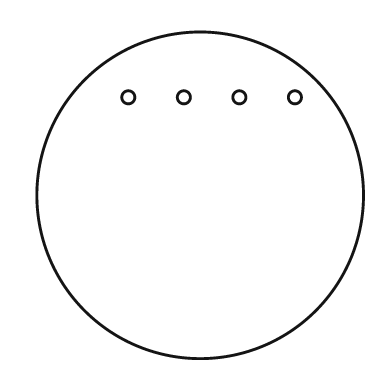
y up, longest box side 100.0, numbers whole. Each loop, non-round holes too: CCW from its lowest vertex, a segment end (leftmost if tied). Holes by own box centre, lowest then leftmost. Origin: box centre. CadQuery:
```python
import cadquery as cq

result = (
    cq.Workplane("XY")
    .moveTo(0.0, 0.0)
    .circle(50.0)
    .moveTo(-22.0, 30.0)
    .circle(2.0)
    .moveTo(-5.0, 30.0)
    .circle(2.0)
    .moveTo(12.0, 30.0)
    .circle(2.0)
    .moveTo(29.0, 30.0)
    .circle(2.0)
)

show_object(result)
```